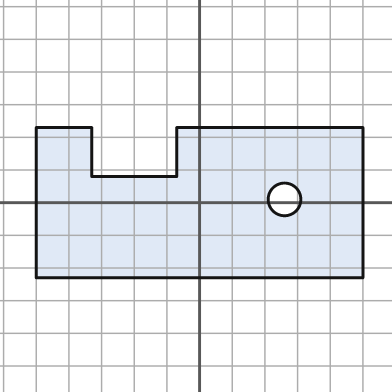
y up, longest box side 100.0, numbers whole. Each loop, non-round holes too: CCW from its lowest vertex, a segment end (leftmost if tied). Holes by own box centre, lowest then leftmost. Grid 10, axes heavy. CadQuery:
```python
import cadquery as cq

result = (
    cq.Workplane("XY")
    .moveTo(-50.0, -23.0)
    .lineTo(50.0, -23.0)
    .lineTo(50.0, 23.0)
    .lineTo(-7.0, 23.0)
    .lineTo(-7.0, 8.0)
    .lineTo(-33.0, 8.0)
    .lineTo(-33.0, 23.0)
    .lineTo(-50.0, 23.0)
    .close()
    .moveTo(26.0, 1.0)
    .circle(5.0)
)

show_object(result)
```